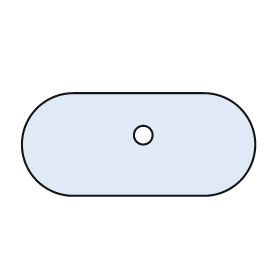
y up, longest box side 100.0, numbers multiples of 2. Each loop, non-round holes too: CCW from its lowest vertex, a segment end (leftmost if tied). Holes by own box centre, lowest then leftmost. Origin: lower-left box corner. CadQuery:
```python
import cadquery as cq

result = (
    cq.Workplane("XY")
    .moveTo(22.0, 0.0)
    .lineTo(78.0, 0.0)
    .threePointArc((100.0, 22.0), (78.0, 44.0))
    .lineTo(22.0, 44.0)
    .threePointArc((0.0, 22.0), (22.0, 0.0))
    .close()
    .moveTo(52.0, 26.0)
    .circle(4.0)
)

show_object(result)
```